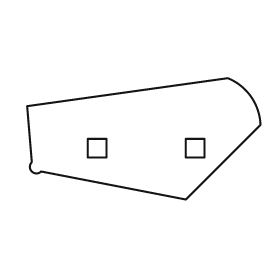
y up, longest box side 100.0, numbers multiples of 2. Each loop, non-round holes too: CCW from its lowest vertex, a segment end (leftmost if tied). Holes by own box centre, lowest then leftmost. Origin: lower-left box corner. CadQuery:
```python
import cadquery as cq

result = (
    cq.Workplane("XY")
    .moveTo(68.0, 0.0)
    .lineTo(100.0, 32.0)
    .threePointArc((96.0, 44.0), (86.0, 52.0))
    .lineTo(0.0, 40.0)
    .lineTo(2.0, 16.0)
    .threePointArc((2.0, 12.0), (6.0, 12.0))
    .close()
    .moveTo(26.0, 18.0)
    .lineTo(34.0, 18.0)
    .lineTo(34.0, 26.0)
    .lineTo(26.0, 26.0)
    .close()
    .moveTo(68.0, 18.0)
    .lineTo(76.0, 18.0)
    .lineTo(76.0, 26.0)
    .lineTo(68.0, 26.0)
    .close()
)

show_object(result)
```